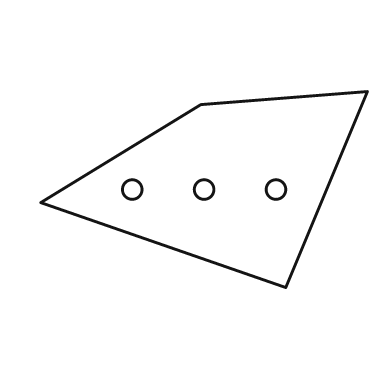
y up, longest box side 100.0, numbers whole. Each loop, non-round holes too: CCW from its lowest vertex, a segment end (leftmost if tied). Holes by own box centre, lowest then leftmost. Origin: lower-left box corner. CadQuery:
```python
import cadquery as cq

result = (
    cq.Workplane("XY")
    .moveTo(75.0, 0.0)
    .lineTo(100.0, 60.0)
    .lineTo(49.0, 56.0)
    .lineTo(0.0, 26.0)
    .close()
    .moveTo(28.0, 30.0)
    .circle(3.0)
    .moveTo(50.0, 30.0)
    .circle(3.0)
    .moveTo(72.0, 30.0)
    .circle(3.0)
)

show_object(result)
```